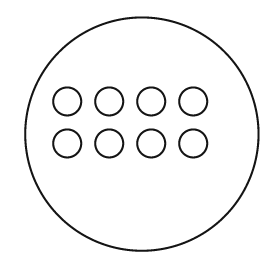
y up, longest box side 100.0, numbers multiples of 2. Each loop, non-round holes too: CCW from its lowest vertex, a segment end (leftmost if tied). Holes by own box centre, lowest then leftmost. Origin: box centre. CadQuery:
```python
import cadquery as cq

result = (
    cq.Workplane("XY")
    .moveTo(0.0, 0.0)
    .circle(50.0)
    .moveTo(-32.0, -4.0)
    .circle(6.0)
    .moveTo(-14.0, -4.0)
    .circle(6.0)
    .moveTo(4.0, -4.0)
    .circle(6.0)
    .moveTo(22.0, -4.0)
    .circle(6.0)
    .moveTo(-32.0, 14.0)
    .circle(6.0)
    .moveTo(-14.0, 14.0)
    .circle(6.0)
    .moveTo(4.0, 14.0)
    .circle(6.0)
    .moveTo(22.0, 14.0)
    .circle(6.0)
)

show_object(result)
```